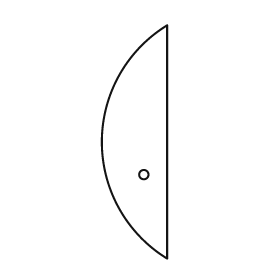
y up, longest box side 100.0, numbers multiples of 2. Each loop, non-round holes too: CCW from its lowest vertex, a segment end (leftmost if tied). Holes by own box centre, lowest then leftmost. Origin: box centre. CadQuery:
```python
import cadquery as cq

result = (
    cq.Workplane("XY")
    .moveTo(14.0, -50.0)
    .lineTo(14.0, 50.0)
    .threePointArc((-14.0, 0.0), (14.0, -50.0))
    .close()
    .moveTo(4.0, -14.0)
    .circle(2.0)
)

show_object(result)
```